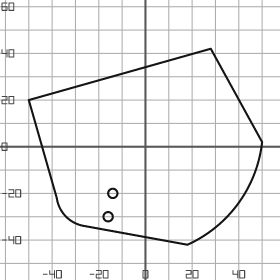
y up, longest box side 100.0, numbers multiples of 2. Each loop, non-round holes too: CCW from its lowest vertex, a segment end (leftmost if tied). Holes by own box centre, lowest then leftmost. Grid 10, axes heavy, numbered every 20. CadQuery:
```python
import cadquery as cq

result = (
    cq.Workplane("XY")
    .moveTo(18.0, -42.0)
    .threePointArc((40.0, -24.0), (50.0, 2.0))
    .lineTo(28.0, 42.0)
    .lineTo(-50.0, 20.0)
    .lineTo(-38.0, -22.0)
    .threePointArc((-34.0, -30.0), (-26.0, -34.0))
    .close()
    .moveTo(-16.0, -30.0)
    .circle(2.0)
    .moveTo(-14.0, -20.0)
    .circle(2.0)
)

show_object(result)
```